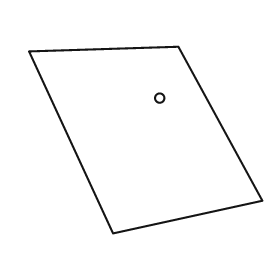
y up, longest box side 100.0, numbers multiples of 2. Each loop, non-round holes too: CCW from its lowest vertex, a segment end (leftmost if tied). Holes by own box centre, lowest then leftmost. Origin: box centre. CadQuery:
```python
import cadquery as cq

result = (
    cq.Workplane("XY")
    .moveTo(-14.0, -40.0)
    .lineTo(50.0, -26.0)
    .lineTo(14.0, 40.0)
    .lineTo(-50.0, 38.0)
    .close()
    .moveTo(6.0, 18.0)
    .circle(2.0)
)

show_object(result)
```